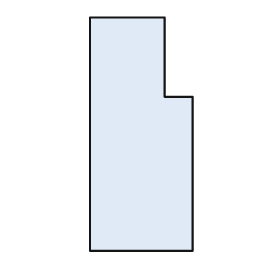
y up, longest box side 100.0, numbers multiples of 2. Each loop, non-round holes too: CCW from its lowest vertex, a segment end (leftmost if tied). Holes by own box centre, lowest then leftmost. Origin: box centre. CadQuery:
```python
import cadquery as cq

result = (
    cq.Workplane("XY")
    .moveTo(-22.0, -50.0)
    .lineTo(22.0, -50.0)
    .lineTo(22.0, 16.0)
    .lineTo(10.0, 16.0)
    .lineTo(10.0, 50.0)
    .lineTo(-22.0, 50.0)
    .close()
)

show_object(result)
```